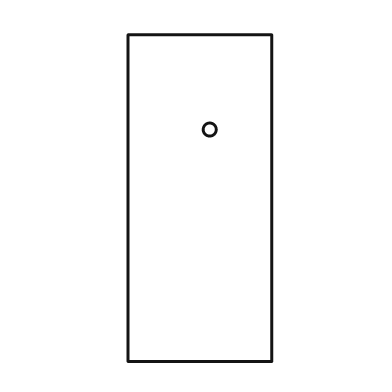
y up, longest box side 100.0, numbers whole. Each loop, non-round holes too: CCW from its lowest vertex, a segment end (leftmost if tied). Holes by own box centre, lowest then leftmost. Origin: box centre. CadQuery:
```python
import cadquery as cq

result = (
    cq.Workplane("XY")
    .moveTo(-22.0, -50.0)
    .lineTo(22.0, -50.0)
    .lineTo(22.0, 50.0)
    .lineTo(-22.0, 50.0)
    .close()
    .moveTo(3.0, 21.0)
    .circle(2.0)
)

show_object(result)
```